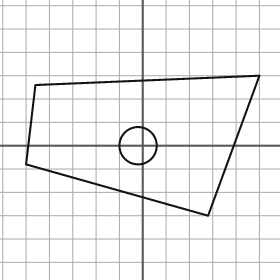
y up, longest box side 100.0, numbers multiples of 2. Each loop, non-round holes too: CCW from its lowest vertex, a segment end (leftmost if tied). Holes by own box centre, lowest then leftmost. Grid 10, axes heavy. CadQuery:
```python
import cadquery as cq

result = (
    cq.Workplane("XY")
    .moveTo(28.0, -30.0)
    .lineTo(50.0, 30.0)
    .lineTo(-46.0, 26.0)
    .lineTo(-50.0, -8.0)
    .close()
    .moveTo(-2.0, 0.0)
    .circle(8.0)
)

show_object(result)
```